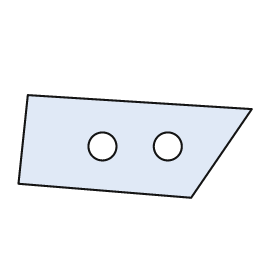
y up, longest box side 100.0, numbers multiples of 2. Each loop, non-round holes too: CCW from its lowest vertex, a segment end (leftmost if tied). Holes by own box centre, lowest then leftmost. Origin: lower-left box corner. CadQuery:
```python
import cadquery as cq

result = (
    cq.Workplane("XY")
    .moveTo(74.0, 0.0)
    .lineTo(100.0, 38.0)
    .lineTo(4.0, 44.0)
    .lineTo(0.0, 6.0)
    .close()
    .moveTo(36.0, 22.0)
    .circle(6.0)
    .moveTo(64.0, 22.0)
    .circle(6.0)
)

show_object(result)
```